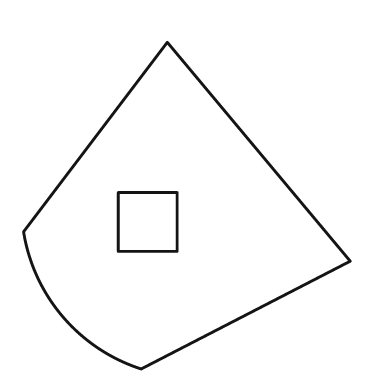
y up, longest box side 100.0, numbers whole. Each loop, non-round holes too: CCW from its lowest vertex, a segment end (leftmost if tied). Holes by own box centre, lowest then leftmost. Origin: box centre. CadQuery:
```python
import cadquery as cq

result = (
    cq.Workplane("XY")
    .moveTo(-14.0, -50.0)
    .lineTo(50.0, -17.0)
    .lineTo(-6.0, 50.0)
    .lineTo(-50.0, -8.0)
    .threePointArc((-38.0, -34.0), (-14.0, -50.0))
    .close()
    .moveTo(-21.0, -14.0)
    .lineTo(-3.0, -14.0)
    .lineTo(-3.0, 4.0)
    .lineTo(-21.0, 4.0)
    .close()
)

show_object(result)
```